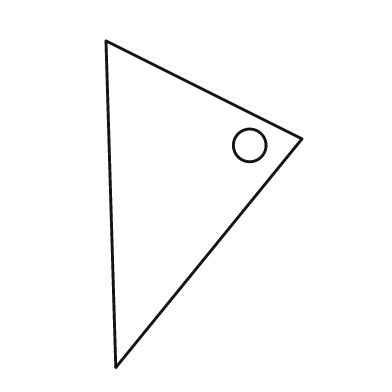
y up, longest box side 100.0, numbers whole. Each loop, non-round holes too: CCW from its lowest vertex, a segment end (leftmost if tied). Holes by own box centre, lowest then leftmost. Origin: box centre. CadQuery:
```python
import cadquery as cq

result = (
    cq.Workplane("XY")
    .moveTo(-27.0, -50.0)
    .lineTo(30.0, 20.0)
    .lineTo(-30.0, 50.0)
    .close()
    .moveTo(14.0, 18.0)
    .circle(5.0)
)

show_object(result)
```